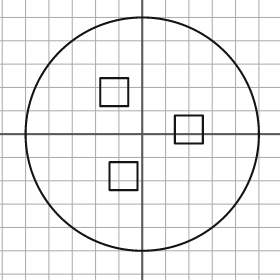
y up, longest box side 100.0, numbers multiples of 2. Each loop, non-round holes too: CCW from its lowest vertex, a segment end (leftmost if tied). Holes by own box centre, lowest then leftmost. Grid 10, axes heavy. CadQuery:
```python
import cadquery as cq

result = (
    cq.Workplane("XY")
    .moveTo(0.0, 0.0)
    .circle(50.0)
    .moveTo(-14.0, -24.0)
    .lineTo(-2.0, -24.0)
    .lineTo(-2.0, -12.0)
    .lineTo(-14.0, -12.0)
    .close()
    .moveTo(14.0, -4.0)
    .lineTo(26.0, -4.0)
    .lineTo(26.0, 8.0)
    .lineTo(14.0, 8.0)
    .close()
    .moveTo(-18.0, 12.0)
    .lineTo(-6.0, 12.0)
    .lineTo(-6.0, 24.0)
    .lineTo(-18.0, 24.0)
    .close()
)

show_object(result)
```